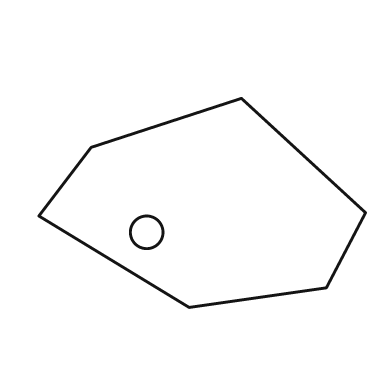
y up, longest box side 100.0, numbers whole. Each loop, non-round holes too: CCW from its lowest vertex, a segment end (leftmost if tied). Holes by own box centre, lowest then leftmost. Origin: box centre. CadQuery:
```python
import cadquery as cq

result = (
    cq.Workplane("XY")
    .moveTo(-4.0, -32.0)
    .lineTo(38.0, -26.0)
    .lineTo(50.0, -3.0)
    .lineTo(12.0, 32.0)
    .lineTo(-34.0, 17.0)
    .lineTo(-50.0, -4.0)
    .close()
    .moveTo(-17.0, -9.0)
    .circle(5.0)
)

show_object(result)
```